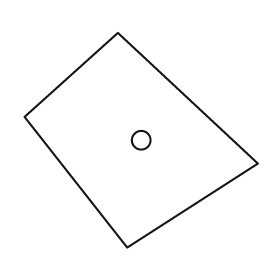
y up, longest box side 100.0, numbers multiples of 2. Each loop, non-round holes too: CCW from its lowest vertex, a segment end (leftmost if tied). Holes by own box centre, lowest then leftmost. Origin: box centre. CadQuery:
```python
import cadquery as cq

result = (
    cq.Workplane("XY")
    .moveTo(-6.0, -46.0)
    .lineTo(50.0, -10.0)
    .lineTo(-10.0, 46.0)
    .lineTo(-50.0, 10.0)
    .close()
    .moveTo(0.0, 0.0)
    .circle(4.0)
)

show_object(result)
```